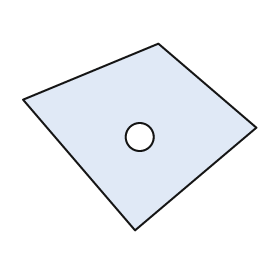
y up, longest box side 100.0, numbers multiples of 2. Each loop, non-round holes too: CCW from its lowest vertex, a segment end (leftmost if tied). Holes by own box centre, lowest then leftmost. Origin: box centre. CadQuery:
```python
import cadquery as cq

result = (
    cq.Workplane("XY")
    .moveTo(-2.0, -40.0)
    .lineTo(50.0, 4.0)
    .lineTo(8.0, 40.0)
    .lineTo(-50.0, 16.0)
    .close()
    .moveTo(0.0, 0.0)
    .circle(6.0)
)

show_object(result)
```